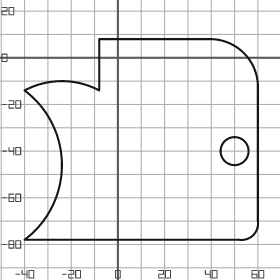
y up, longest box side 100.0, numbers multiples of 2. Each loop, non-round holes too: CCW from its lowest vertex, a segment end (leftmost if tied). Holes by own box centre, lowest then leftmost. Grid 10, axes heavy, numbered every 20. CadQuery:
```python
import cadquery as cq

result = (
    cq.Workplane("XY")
    .moveTo(-40.0, -78.0)
    .lineTo(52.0, -78.0)
    .threePointArc((58.0, -76.0), (60.0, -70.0))
    .lineTo(60.0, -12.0)
    .threePointArc((54.0, 2.0), (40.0, 8.0))
    .lineTo(-8.0, 8.0)
    .lineTo(-8.0, -14.0)
    .threePointArc((-24.0, -10.0), (-40.0, -14.0))
    .threePointArc((-24.0, -46.0), (-40.0, -78.0))
    .close()
    .moveTo(50.0, -40.0)
    .circle(6.0)
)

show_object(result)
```